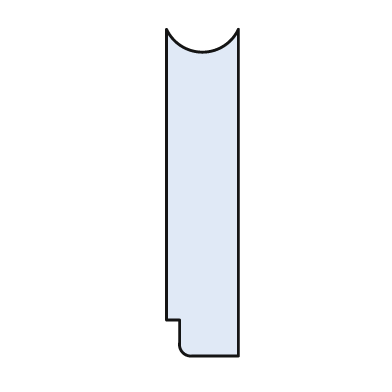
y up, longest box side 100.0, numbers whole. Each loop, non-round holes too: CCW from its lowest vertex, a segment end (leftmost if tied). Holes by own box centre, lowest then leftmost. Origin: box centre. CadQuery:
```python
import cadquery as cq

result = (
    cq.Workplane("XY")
    .moveTo(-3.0, -50.0)
    .lineTo(11.0, -50.0)
    .lineTo(11.0, 50.0)
    .threePointArc((0.0, 43.0), (-11.0, 50.0))
    .lineTo(-11.0, -39.0)
    .lineTo(-7.0, -39.0)
    .lineTo(-7.0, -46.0)
    .threePointArc((-6.0, -49.0), (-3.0, -50.0))
    .close()
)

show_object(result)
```